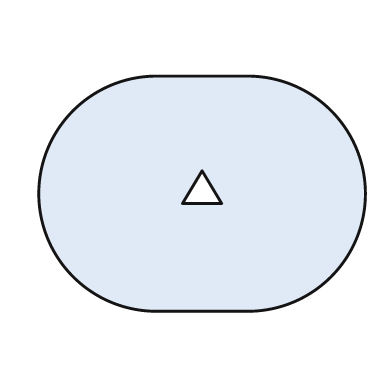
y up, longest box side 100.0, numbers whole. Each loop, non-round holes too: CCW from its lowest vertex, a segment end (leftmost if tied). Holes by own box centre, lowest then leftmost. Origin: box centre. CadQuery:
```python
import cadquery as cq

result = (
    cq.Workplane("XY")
    .moveTo(-14.0, -36.0)
    .lineTo(14.0, -36.0)
    .threePointArc((50.0, 0.0), (14.0, 36.0))
    .lineTo(-14.0, 36.0)
    .threePointArc((-50.0, 0.0), (-14.0, -36.0))
    .close()
    .moveTo(-6.0, -3.0)
    .lineTo(6.0, -3.0)
    .lineTo(0.0, 7.0)
    .close()
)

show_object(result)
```